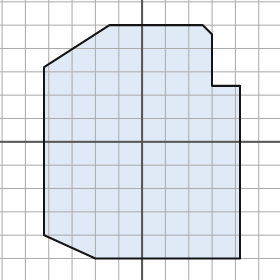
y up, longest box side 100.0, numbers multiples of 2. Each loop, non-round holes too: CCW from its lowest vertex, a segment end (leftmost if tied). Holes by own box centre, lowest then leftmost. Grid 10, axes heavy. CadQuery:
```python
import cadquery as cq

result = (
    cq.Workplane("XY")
    .moveTo(-20.0, -50.0)
    .lineTo(42.0, -50.0)
    .lineTo(42.0, 24.0)
    .lineTo(30.0, 24.0)
    .lineTo(30.0, 46.0)
    .lineTo(26.0, 50.0)
    .lineTo(-14.0, 50.0)
    .lineTo(-42.0, 32.0)
    .lineTo(-42.0, -40.0)
    .close()
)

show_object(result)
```